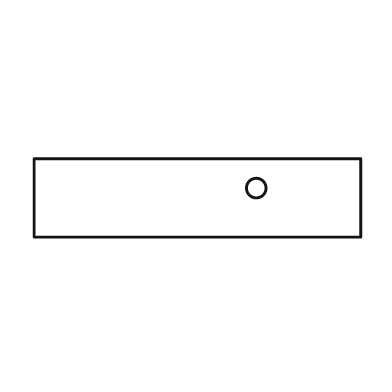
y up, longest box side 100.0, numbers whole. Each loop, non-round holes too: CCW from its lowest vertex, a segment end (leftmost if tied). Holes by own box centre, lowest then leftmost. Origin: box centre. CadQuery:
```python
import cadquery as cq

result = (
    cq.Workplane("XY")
    .moveTo(-50.0, -12.0)
    .lineTo(50.0, -12.0)
    .lineTo(50.0, 12.0)
    .lineTo(-50.0, 12.0)
    .close()
    .moveTo(18.0, 3.0)
    .circle(3.0)
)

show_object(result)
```